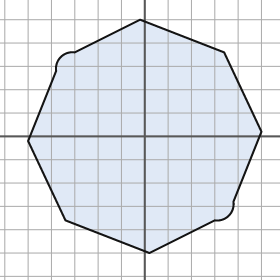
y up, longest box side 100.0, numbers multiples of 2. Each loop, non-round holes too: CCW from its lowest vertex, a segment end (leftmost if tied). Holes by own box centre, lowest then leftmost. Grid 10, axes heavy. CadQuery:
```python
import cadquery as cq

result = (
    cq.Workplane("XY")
    .moveTo(2.0, -50.0)
    .lineTo(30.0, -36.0)
    .threePointArc((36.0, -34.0), (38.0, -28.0))
    .lineTo(50.0, 2.0)
    .lineTo(34.0, 36.0)
    .lineTo(-2.0, 50.0)
    .lineTo(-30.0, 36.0)
    .threePointArc((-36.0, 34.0), (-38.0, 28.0))
    .lineTo(-50.0, -2.0)
    .lineTo(-34.0, -36.0)
    .close()
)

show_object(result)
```